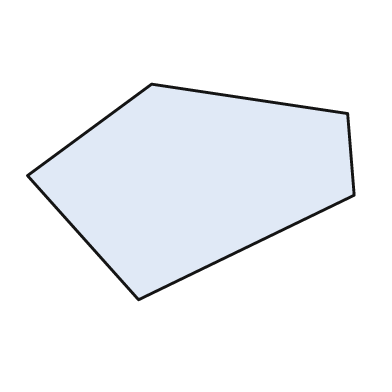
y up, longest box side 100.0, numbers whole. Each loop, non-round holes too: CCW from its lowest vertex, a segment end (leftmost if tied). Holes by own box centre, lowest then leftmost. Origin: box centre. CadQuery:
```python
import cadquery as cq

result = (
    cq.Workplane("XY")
    .moveTo(-16.0, -33.0)
    .lineTo(50.0, -1.0)
    .lineTo(48.0, 24.0)
    .lineTo(-12.0, 33.0)
    .lineTo(-50.0, 5.0)
    .close()
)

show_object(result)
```